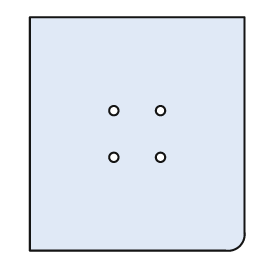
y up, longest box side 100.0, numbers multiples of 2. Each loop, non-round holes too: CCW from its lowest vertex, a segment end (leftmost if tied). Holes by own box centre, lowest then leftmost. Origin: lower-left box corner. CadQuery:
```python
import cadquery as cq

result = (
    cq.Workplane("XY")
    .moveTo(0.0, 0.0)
    .lineTo(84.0, 0.0)
    .threePointArc((90.0, 2.0), (92.0, 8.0))
    .lineTo(92.0, 100.0)
    .lineTo(0.0, 100.0)
    .close()
    .moveTo(36.0, 40.0)
    .circle(2.0)
    .moveTo(56.0, 40.0)
    .circle(2.0)
    .moveTo(36.0, 60.0)
    .circle(2.0)
    .moveTo(56.0, 60.0)
    .circle(2.0)
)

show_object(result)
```